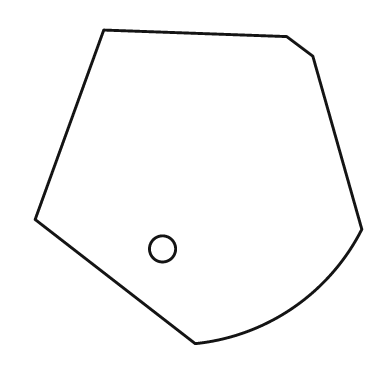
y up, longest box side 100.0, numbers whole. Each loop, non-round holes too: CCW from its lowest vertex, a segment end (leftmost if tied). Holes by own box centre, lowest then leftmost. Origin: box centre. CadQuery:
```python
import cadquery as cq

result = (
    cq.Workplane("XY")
    .moveTo(-1.0, -48.0)
    .threePointArc((29.0, -37.0), (50.0, -13.0))
    .lineTo(35.0, 40.0)
    .lineTo(27.0, 46.0)
    .lineTo(-29.0, 48.0)
    .lineTo(-50.0, -10.0)
    .close()
    .moveTo(-11.0, -19.0)
    .circle(4.0)
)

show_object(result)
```